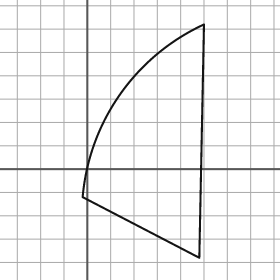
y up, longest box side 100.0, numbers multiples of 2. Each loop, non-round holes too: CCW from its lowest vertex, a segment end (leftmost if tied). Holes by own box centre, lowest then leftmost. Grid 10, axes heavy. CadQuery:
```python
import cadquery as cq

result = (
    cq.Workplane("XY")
    .moveTo(48.0, -38.0)
    .lineTo(50.0, 62.0)
    .threePointArc((14.0, 32.0), (-2.0, -12.0))
    .close()
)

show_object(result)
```